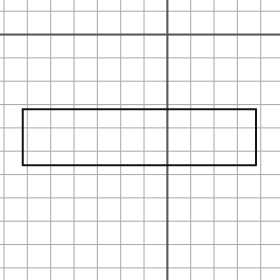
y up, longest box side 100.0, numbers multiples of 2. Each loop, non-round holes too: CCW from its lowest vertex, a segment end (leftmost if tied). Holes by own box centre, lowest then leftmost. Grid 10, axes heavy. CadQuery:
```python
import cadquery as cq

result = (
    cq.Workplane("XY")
    .moveTo(-62.0, -56.0)
    .lineTo(38.0, -56.0)
    .lineTo(38.0, -32.0)
    .lineTo(-62.0, -32.0)
    .close()
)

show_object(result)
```